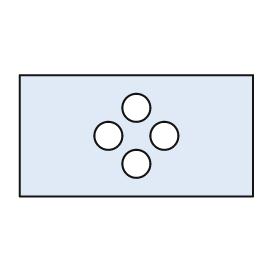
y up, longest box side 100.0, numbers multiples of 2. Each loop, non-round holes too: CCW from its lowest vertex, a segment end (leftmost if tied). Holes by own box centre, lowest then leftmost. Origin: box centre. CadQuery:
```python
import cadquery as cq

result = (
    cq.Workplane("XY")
    .moveTo(-50.0, -26.0)
    .lineTo(50.0, -26.0)
    .lineTo(50.0, 26.0)
    .lineTo(-50.0, 26.0)
    .close()
    .moveTo(0.0, -12.0)
    .circle(6.0)
    .moveTo(-12.0, 0.0)
    .circle(6.0)
    .moveTo(12.0, 0.0)
    .circle(6.0)
    .moveTo(0.0, 12.0)
    .circle(6.0)
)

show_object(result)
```